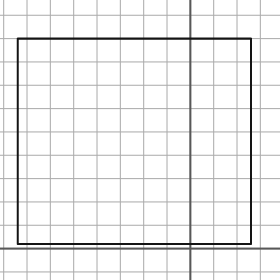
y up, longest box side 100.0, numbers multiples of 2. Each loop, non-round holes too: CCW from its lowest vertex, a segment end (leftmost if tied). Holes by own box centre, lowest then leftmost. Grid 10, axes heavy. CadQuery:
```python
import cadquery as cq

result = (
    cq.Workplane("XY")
    .moveTo(-74.0, 2.0)
    .lineTo(26.0, 2.0)
    .lineTo(26.0, 90.0)
    .lineTo(-74.0, 90.0)
    .close()
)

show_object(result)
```